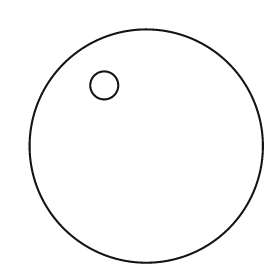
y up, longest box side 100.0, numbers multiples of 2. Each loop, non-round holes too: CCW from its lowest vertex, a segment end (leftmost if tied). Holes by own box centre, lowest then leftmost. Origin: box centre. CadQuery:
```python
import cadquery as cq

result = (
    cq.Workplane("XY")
    .moveTo(0.0, 0.0)
    .circle(50.0)
    .moveTo(-18.0, 26.0)
    .circle(6.0)
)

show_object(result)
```